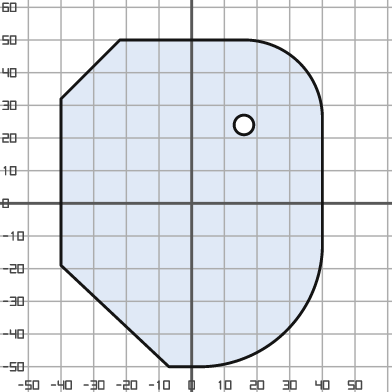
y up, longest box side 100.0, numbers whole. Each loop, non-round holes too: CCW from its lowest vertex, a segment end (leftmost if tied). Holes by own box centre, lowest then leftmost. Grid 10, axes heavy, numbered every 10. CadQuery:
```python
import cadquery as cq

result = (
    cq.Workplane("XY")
    .moveTo(-7.0, -50.0)
    .lineTo(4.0, -50.0)
    .threePointArc((29.0, -39.0), (40.0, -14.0))
    .lineTo(40.0, 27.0)
    .threePointArc((33.0, 43.0), (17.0, 50.0))
    .lineTo(-22.0, 50.0)
    .lineTo(-40.0, 32.0)
    .lineTo(-40.0, -19.0)
    .close()
    .moveTo(16.0, 24.0)
    .circle(3.0)
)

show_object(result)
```